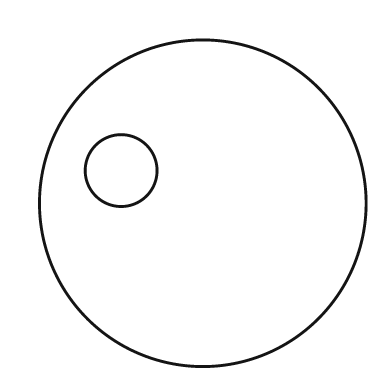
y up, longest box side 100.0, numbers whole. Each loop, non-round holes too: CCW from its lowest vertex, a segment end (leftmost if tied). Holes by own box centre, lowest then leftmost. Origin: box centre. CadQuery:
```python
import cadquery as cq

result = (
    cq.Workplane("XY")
    .moveTo(0.0, 0.0)
    .circle(50.0)
    .moveTo(-25.0, 10.0)
    .circle(11.0)
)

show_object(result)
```